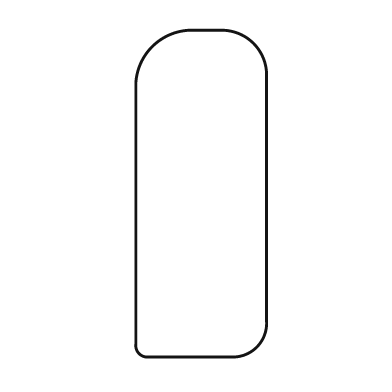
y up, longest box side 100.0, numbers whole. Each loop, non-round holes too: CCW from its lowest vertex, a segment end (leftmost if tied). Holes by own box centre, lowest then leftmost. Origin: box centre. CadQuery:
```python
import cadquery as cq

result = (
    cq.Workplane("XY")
    .moveTo(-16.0, -50.0)
    .lineTo(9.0, -50.0)
    .threePointArc((17.0, -47.0), (20.0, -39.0))
    .lineTo(20.0, 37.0)
    .threePointArc((16.0, 46.0), (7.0, 50.0))
    .lineTo(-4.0, 50.0)
    .threePointArc((-15.0, 45.0), (-20.0, 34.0))
    .lineTo(-20.0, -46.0)
    .threePointArc((-19.0, -49.0), (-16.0, -50.0))
    .close()
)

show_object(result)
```